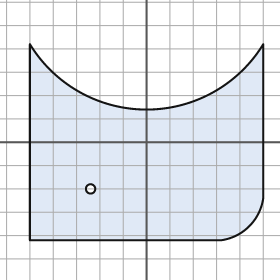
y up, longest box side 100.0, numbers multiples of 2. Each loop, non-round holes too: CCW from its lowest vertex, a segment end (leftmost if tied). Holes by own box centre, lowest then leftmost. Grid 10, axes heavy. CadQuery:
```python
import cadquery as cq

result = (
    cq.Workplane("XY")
    .moveTo(-50.0, -42.0)
    .lineTo(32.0, -42.0)
    .threePointArc((44.0, -36.0), (50.0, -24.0))
    .lineTo(50.0, 42.0)
    .threePointArc((0.0, 14.0), (-50.0, 42.0))
    .close()
    .moveTo(-24.0, -20.0)
    .circle(2.0)
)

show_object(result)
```